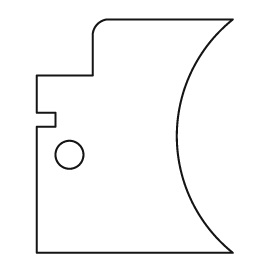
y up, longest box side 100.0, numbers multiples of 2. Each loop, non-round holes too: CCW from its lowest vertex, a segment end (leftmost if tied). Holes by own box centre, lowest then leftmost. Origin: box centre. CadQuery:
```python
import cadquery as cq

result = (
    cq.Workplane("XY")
    .moveTo(-42.0, -50.0)
    .lineTo(42.0, -50.0)
    .threePointArc((18.0, 0.0), (42.0, 50.0))
    .lineTo(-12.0, 50.0)
    .threePointArc((-16.0, 48.0), (-18.0, 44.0))
    .lineTo(-18.0, 26.0)
    .lineTo(-42.0, 26.0)
    .lineTo(-42.0, 10.0)
    .lineTo(-34.0, 10.0)
    .lineTo(-34.0, 4.0)
    .lineTo(-42.0, 4.0)
    .close()
    .moveTo(-28.0, -8.0)
    .circle(6.0)
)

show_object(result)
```